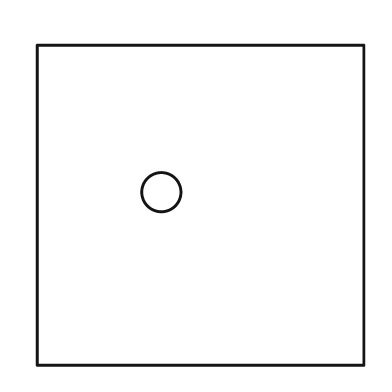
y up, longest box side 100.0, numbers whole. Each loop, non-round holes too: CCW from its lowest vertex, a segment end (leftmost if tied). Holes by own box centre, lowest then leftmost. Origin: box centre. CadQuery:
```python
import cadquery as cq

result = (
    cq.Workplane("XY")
    .moveTo(-50.0, -49.0)
    .lineTo(50.0, -49.0)
    .lineTo(50.0, 49.0)
    .lineTo(-50.0, 49.0)
    .close()
    .moveTo(-12.0, 4.0)
    .circle(6.0)
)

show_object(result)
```